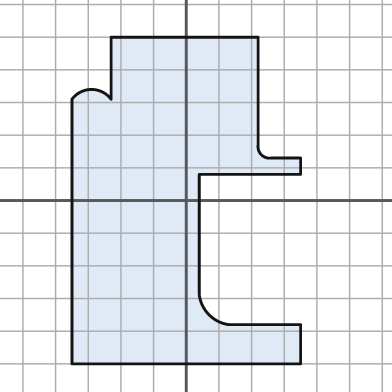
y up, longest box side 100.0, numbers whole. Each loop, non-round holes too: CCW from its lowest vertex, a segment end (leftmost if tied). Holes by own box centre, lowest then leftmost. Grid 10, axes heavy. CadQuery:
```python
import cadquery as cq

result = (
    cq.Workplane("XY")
    .moveTo(-35.0, -50.0)
    .lineTo(35.0, -50.0)
    .lineTo(35.0, -38.0)
    .lineTo(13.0, -38.0)
    .threePointArc((7.0, -35.0), (4.0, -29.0))
    .lineTo(4.0, 8.0)
    .lineTo(35.0, 8.0)
    .lineTo(35.0, 13.0)
    .lineTo(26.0, 13.0)
    .threePointArc((23.0, 14.0), (22.0, 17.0))
    .lineTo(22.0, 50.0)
    .lineTo(-23.0, 50.0)
    .lineTo(-23.0, 31.0)
    .threePointArc((-29.0, 34.0), (-35.0, 31.0))
    .close()
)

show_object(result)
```